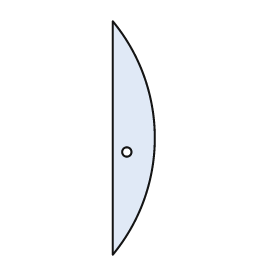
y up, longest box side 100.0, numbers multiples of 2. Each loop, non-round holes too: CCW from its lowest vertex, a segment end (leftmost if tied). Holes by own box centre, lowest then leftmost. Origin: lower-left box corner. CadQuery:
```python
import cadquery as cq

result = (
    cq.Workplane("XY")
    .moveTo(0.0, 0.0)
    .threePointArc((18.0, 50.0), (0.0, 100.0))
    .close()
    .moveTo(6.0, 44.0)
    .circle(2.0)
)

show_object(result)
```